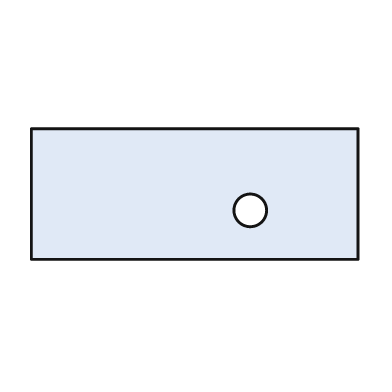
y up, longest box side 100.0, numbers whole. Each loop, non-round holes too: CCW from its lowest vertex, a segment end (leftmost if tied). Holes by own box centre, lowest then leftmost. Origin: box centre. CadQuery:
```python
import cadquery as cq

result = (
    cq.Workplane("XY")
    .moveTo(-50.0, -20.0)
    .lineTo(50.0, -20.0)
    .lineTo(50.0, 20.0)
    .lineTo(-50.0, 20.0)
    .close()
    .moveTo(17.0, -5.0)
    .circle(5.0)
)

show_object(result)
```